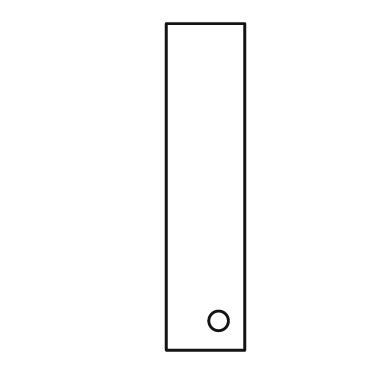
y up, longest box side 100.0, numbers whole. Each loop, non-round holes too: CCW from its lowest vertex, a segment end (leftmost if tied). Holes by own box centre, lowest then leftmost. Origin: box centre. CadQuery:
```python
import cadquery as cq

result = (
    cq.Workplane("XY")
    .moveTo(-12.0, -50.0)
    .lineTo(12.0, -50.0)
    .lineTo(12.0, 50.0)
    .lineTo(-12.0, 50.0)
    .close()
    .moveTo(4.0, -41.0)
    .circle(3.0)
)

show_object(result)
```